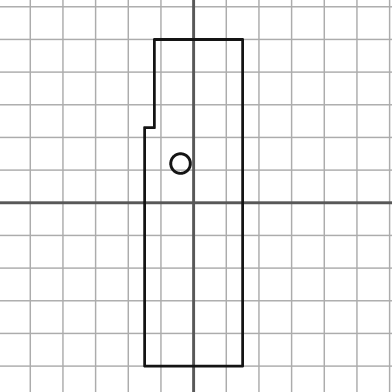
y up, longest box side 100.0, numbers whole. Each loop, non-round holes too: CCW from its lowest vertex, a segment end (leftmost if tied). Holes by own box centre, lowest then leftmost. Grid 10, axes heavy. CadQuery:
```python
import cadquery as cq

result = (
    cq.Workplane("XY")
    .moveTo(-15.0, -50.0)
    .lineTo(15.0, -50.0)
    .lineTo(15.0, 50.0)
    .lineTo(-12.0, 50.0)
    .lineTo(-12.0, 23.0)
    .lineTo(-15.0, 23.0)
    .close()
    .moveTo(-4.0, 12.0)
    .circle(3.0)
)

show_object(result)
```